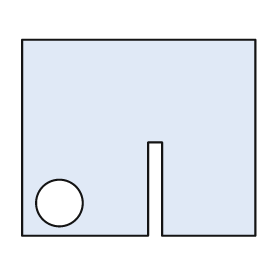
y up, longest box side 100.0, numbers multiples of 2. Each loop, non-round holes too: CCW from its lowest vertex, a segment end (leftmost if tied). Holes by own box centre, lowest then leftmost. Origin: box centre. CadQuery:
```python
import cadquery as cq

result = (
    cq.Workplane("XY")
    .moveTo(-50.0, -42.0)
    .lineTo(4.0, -42.0)
    .lineTo(4.0, -2.0)
    .lineTo(10.0, -2.0)
    .lineTo(10.0, -42.0)
    .lineTo(50.0, -42.0)
    .lineTo(50.0, 42.0)
    .lineTo(-50.0, 42.0)
    .close()
    .moveTo(-34.0, -28.0)
    .circle(10.0)
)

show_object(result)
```